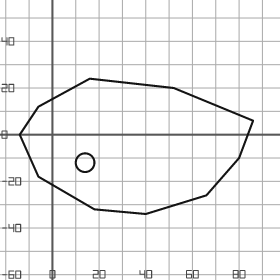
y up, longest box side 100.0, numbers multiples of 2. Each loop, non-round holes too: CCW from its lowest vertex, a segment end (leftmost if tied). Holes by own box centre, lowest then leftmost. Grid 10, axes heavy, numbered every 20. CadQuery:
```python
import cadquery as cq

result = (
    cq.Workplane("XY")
    .moveTo(40.0, -34.0)
    .lineTo(66.0, -26.0)
    .lineTo(80.0, -10.0)
    .lineTo(86.0, 6.0)
    .lineTo(52.0, 20.0)
    .lineTo(16.0, 24.0)
    .lineTo(-6.0, 12.0)
    .lineTo(-14.0, 0.0)
    .lineTo(-6.0, -18.0)
    .lineTo(18.0, -32.0)
    .close()
    .moveTo(14.0, -12.0)
    .circle(4.0)
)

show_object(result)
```